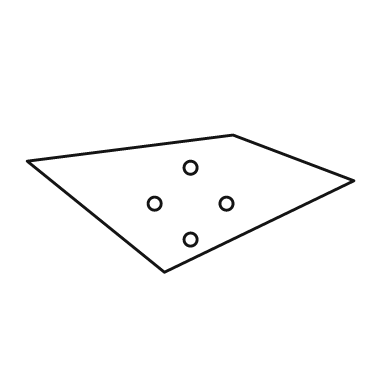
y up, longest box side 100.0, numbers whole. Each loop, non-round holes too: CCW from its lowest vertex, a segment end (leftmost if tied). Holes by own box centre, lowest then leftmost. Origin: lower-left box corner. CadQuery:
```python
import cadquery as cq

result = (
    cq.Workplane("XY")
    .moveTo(42.0, 0.0)
    .lineTo(100.0, 28.0)
    .lineTo(63.0, 42.0)
    .lineTo(0.0, 34.0)
    .close()
    .moveTo(50.0, 10.0)
    .circle(2.0)
    .moveTo(39.0, 21.0)
    .circle(2.0)
    .moveTo(61.0, 21.0)
    .circle(2.0)
    .moveTo(50.0, 32.0)
    .circle(2.0)
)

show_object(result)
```